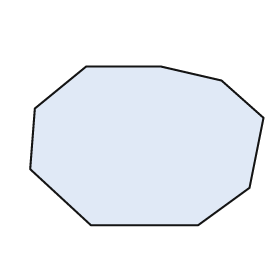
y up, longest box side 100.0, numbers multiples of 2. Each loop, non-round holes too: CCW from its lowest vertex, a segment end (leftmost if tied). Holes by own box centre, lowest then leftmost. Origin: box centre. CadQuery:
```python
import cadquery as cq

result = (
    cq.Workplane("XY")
    .moveTo(-24.0, -34.0)
    .lineTo(22.0, -34.0)
    .lineTo(44.0, -18.0)
    .lineTo(50.0, 12.0)
    .lineTo(32.0, 28.0)
    .lineTo(6.0, 34.0)
    .lineTo(-26.0, 34.0)
    .lineTo(-48.0, 16.0)
    .lineTo(-50.0, -10.0)
    .close()
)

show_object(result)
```